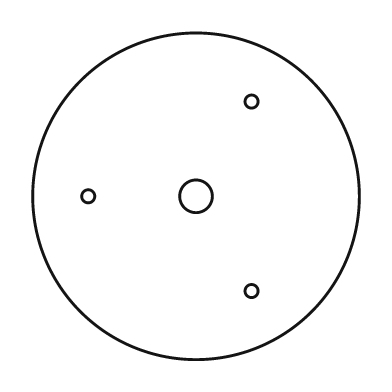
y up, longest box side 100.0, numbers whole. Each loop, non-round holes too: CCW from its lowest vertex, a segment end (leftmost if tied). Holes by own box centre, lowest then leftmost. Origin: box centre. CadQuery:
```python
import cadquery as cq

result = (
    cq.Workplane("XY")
    .moveTo(0.0, 0.0)
    .circle(50.0)
    .moveTo(17.0, -29.0)
    .circle(2.0)
    .moveTo(-33.0, 0.0)
    .circle(2.0)
    .moveTo(0.0, 0.0)
    .circle(5.0)
    .moveTo(17.0, 29.0)
    .circle(2.0)
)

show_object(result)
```